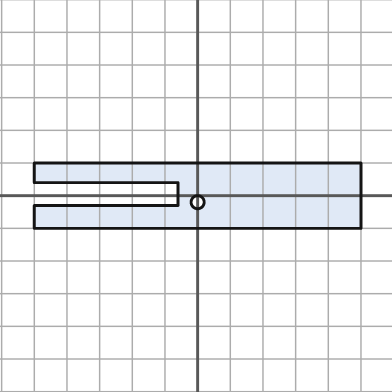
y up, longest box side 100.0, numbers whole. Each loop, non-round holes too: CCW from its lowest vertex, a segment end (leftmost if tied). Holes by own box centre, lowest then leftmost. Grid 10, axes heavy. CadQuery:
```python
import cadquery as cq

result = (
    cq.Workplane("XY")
    .moveTo(-50.0, -10.0)
    .lineTo(50.0, -10.0)
    .lineTo(50.0, 10.0)
    .lineTo(-50.0, 10.0)
    .lineTo(-50.0, 4.0)
    .lineTo(-6.0, 4.0)
    .lineTo(-6.0, -3.0)
    .lineTo(-50.0, -3.0)
    .close()
    .moveTo(0.0, -2.0)
    .circle(2.0)
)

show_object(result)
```